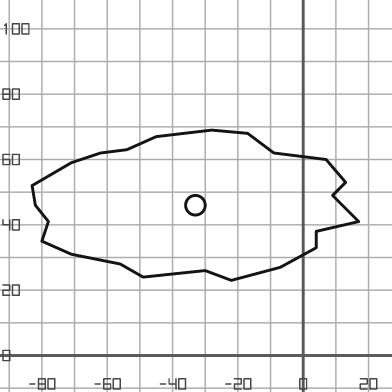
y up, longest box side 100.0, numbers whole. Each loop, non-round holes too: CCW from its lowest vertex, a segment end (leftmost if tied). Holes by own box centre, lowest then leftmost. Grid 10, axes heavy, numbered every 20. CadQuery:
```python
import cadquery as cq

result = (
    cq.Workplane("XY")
    .moveTo(-22.0, 23.0)
    .lineTo(-7.0, 27.0)
    .lineTo(4.0, 33.0)
    .lineTo(4.0, 38.0)
    .lineTo(17.0, 41.0)
    .lineTo(9.0, 49.0)
    .lineTo(13.0, 53.0)
    .lineTo(7.0, 60.0)
    .lineTo(-9.0, 62.0)
    .lineTo(-17.0, 68.0)
    .lineTo(-28.0, 69.0)
    .lineTo(-45.0, 67.0)
    .lineTo(-54.0, 63.0)
    .lineTo(-62.0, 62.0)
    .lineTo(-71.0, 59.0)
    .lineTo(-83.0, 52.0)
    .lineTo(-82.0, 46.0)
    .lineTo(-78.0, 41.0)
    .lineTo(-80.0, 35.0)
    .lineTo(-71.0, 31.0)
    .lineTo(-56.0, 28.0)
    .lineTo(-49.0, 24.0)
    .lineTo(-30.0, 26.0)
    .close()
    .moveTo(-33.0, 46.0)
    .circle(3.0)
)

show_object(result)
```